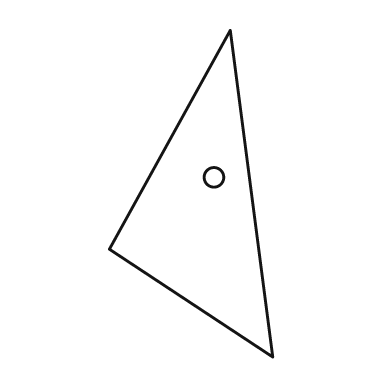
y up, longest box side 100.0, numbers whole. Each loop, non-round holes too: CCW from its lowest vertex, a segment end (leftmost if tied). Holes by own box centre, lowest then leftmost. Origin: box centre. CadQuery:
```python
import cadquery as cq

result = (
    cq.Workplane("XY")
    .moveTo(25.0, -50.0)
    .lineTo(12.0, 50.0)
    .lineTo(-25.0, -17.0)
    .close()
    .moveTo(7.0, 5.0)
    .circle(3.0)
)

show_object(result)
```